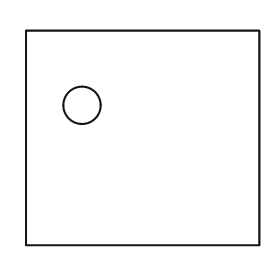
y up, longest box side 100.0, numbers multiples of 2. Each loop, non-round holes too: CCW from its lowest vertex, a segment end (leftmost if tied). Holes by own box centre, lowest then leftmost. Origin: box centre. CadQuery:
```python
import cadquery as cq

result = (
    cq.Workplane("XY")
    .moveTo(-50.0, -46.0)
    .lineTo(50.0, -46.0)
    .lineTo(50.0, 46.0)
    .lineTo(-50.0, 46.0)
    .close()
    .moveTo(-26.0, 14.0)
    .circle(8.0)
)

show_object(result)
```